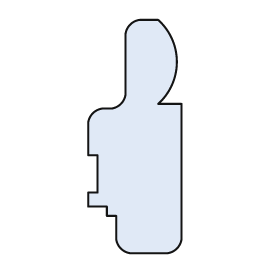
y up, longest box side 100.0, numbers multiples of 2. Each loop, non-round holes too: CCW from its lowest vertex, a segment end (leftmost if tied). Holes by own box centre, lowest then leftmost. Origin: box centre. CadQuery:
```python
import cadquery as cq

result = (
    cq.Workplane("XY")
    .moveTo(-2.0, -50.0)
    .lineTo(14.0, -50.0)
    .threePointArc((18.0, -48.0), (20.0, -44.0))
    .lineTo(20.0, 14.0)
    .lineTo(10.0, 14.0)
    .threePointArc((18.0, 32.0), (10.0, 50.0))
    .lineTo(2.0, 50.0)
    .threePointArc((-2.0, 48.0), (-4.0, 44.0))
    .lineTo(-4.0, 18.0)
    .threePointArc((-6.0, 14.0), (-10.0, 12.0))
    .lineTo(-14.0, 12.0)
    .threePointArc((-18.0, 10.0), (-20.0, 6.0))
    .lineTo(-20.0, -8.0)
    .lineTo(-16.0, -8.0)
    .lineTo(-16.0, -24.0)
    .lineTo(-20.0, -24.0)
    .lineTo(-20.0, -30.0)
    .lineTo(-12.0, -30.0)
    .lineTo(-12.0, -34.0)
    .lineTo(-8.0, -34.0)
    .lineTo(-8.0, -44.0)
    .threePointArc((-6.0, -48.0), (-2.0, -50.0))
    .close()
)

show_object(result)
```